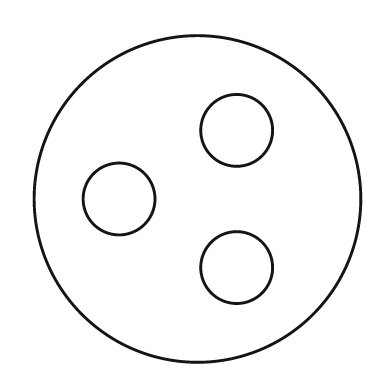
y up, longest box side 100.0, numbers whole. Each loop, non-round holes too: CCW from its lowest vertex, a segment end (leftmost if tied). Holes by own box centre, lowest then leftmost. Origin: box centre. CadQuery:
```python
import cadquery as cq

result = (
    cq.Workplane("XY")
    .moveTo(0.0, 0.0)
    .circle(50.0)
    .moveTo(12.0, -21.0)
    .circle(11.0)
    .moveTo(-24.0, 0.0)
    .circle(11.0)
    .moveTo(12.0, 21.0)
    .circle(11.0)
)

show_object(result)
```